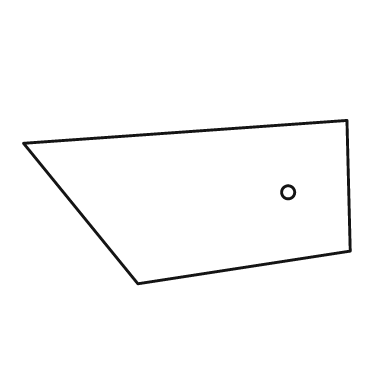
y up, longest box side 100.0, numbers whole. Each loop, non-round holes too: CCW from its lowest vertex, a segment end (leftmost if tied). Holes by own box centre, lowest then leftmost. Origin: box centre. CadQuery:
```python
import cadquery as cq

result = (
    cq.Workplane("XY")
    .moveTo(-15.0, -25.0)
    .lineTo(50.0, -15.0)
    .lineTo(49.0, 25.0)
    .lineTo(-50.0, 18.0)
    .close()
    .moveTo(31.0, 3.0)
    .circle(2.0)
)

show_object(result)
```